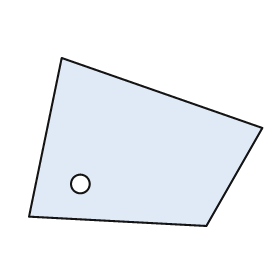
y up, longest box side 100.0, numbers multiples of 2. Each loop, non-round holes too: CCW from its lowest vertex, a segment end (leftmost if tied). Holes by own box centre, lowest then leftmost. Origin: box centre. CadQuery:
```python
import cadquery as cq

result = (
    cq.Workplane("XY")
    .moveTo(26.0, -36.0)
    .lineTo(50.0, 6.0)
    .lineTo(-36.0, 36.0)
    .lineTo(-50.0, -32.0)
    .close()
    .moveTo(-28.0, -18.0)
    .circle(4.0)
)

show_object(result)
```